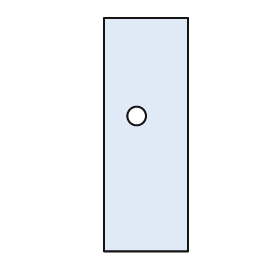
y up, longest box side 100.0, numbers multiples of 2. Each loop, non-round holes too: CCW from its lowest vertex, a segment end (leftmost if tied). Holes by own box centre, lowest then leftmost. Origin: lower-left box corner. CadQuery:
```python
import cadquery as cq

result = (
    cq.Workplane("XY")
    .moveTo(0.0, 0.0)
    .lineTo(36.0, 0.0)
    .lineTo(36.0, 100.0)
    .lineTo(0.0, 100.0)
    .close()
    .moveTo(14.0, 58.0)
    .circle(4.0)
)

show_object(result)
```